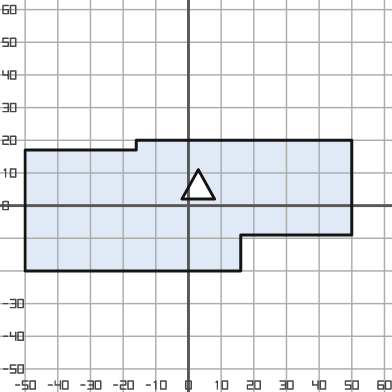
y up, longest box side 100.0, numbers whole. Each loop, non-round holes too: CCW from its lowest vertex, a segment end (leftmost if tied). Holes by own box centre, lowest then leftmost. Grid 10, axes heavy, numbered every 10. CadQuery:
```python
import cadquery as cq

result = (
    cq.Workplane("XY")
    .moveTo(-50.0, -20.0)
    .lineTo(16.0, -20.0)
    .lineTo(16.0, -9.0)
    .lineTo(50.0, -9.0)
    .lineTo(50.0, 20.0)
    .lineTo(-16.0, 20.0)
    .lineTo(-16.0, 17.0)
    .lineTo(-50.0, 17.0)
    .close()
    .moveTo(-2.0, 2.0)
    .lineTo(8.0, 2.0)
    .lineTo(3.0, 11.0)
    .close()
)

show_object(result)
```